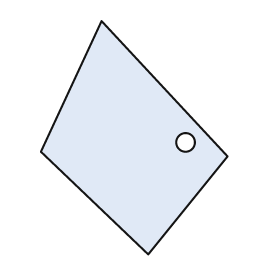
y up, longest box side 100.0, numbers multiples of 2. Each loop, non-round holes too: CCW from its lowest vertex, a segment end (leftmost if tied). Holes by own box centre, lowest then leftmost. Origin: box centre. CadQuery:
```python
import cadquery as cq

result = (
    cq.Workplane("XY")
    .moveTo(6.0, -50.0)
    .lineTo(40.0, -8.0)
    .lineTo(-14.0, 50.0)
    .lineTo(-40.0, -6.0)
    .close()
    .moveTo(22.0, -2.0)
    .circle(4.0)
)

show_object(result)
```